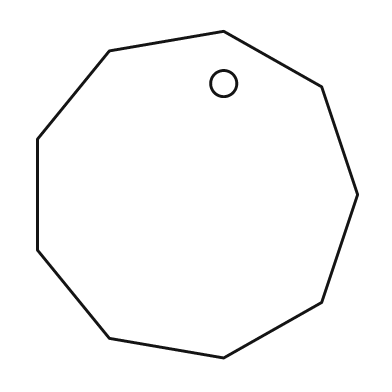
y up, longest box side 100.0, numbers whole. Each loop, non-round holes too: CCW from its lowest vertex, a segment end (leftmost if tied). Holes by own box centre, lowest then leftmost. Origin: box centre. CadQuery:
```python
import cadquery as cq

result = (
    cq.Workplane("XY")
    .moveTo(8.0, -50.0)
    .lineTo(38.0, -33.0)
    .lineTo(49.0, 0.0)
    .lineTo(38.0, 33.0)
    .lineTo(8.0, 50.0)
    .lineTo(-27.0, 44.0)
    .lineTo(-49.0, 17.0)
    .lineTo(-49.0, -17.0)
    .lineTo(-27.0, -44.0)
    .close()
    .moveTo(8.0, 34.0)
    .circle(4.0)
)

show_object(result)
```